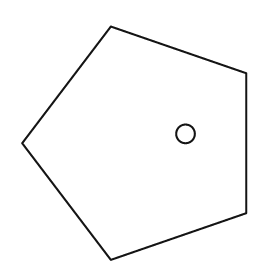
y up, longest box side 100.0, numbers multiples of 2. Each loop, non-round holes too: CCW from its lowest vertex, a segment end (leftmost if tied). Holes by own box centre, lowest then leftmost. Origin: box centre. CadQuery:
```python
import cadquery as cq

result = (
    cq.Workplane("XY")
    .moveTo(-10.0, -50.0)
    .lineTo(48.0, -30.0)
    .lineTo(48.0, 30.0)
    .lineTo(-10.0, 50.0)
    .lineTo(-48.0, 0.0)
    .close()
    .moveTo(22.0, 4.0)
    .circle(4.0)
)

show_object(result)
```